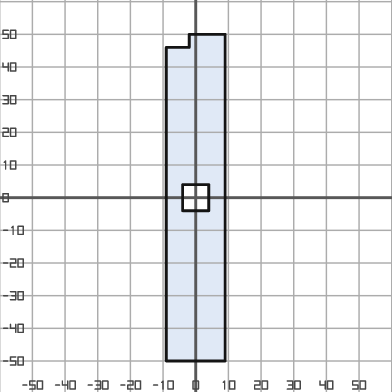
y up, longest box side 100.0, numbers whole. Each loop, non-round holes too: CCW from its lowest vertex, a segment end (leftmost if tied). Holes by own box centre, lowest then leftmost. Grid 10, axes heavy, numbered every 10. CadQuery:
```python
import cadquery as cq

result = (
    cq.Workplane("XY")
    .moveTo(-9.0, -50.0)
    .lineTo(9.0, -50.0)
    .lineTo(9.0, 50.0)
    .lineTo(-2.0, 50.0)
    .lineTo(-2.0, 46.0)
    .lineTo(-9.0, 46.0)
    .close()
    .moveTo(-4.0, -4.0)
    .lineTo(4.0, -4.0)
    .lineTo(4.0, 4.0)
    .lineTo(-4.0, 4.0)
    .close()
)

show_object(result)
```